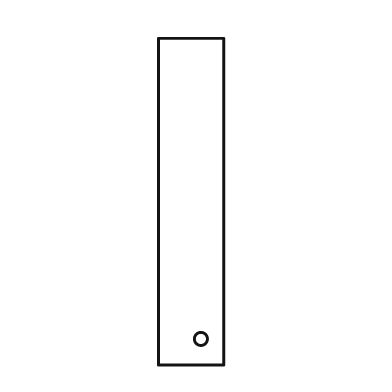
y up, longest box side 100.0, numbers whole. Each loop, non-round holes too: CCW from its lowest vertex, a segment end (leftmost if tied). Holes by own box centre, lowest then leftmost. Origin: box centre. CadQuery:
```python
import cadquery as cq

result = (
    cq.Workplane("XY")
    .moveTo(-10.0, -50.0)
    .lineTo(10.0, -50.0)
    .lineTo(10.0, 50.0)
    .lineTo(-10.0, 50.0)
    .close()
    .moveTo(3.0, -42.0)
    .circle(2.0)
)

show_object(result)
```